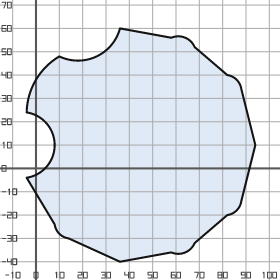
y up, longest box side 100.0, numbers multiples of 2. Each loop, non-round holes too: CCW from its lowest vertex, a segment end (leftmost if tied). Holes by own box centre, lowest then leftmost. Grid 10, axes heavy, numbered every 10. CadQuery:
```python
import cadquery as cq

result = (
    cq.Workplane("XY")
    .moveTo(36.0, -40.0)
    .lineTo(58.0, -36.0)
    .threePointArc((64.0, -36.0), (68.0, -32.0))
    .lineTo(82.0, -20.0)
    .threePointArc((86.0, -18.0), (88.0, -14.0))
    .lineTo(94.0, 10.0)
    .lineTo(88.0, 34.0)
    .threePointArc((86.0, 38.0), (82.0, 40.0))
    .lineTo(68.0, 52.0)
    .threePointArc((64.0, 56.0), (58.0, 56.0))
    .lineTo(36.0, 60.0)
    .threePointArc((26.0, 48.0), (10.0, 48.0))
    .threePointArc((0.0, 38.0), (-4.0, 24.0))
    .threePointArc((8.0, 10.0), (-4.0, -4.0))
    .lineTo(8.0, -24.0)
    .threePointArc((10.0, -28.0), (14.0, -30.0))
    .close()
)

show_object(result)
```